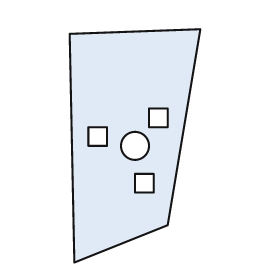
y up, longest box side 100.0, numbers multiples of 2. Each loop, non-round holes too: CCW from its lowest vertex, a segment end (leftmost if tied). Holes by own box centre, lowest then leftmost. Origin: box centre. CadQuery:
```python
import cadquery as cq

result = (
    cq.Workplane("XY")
    .moveTo(-26.0, -50.0)
    .lineTo(14.0, -34.0)
    .lineTo(28.0, 50.0)
    .lineTo(-28.0, 48.0)
    .close()
    .moveTo(0.0, -20.0)
    .lineTo(8.0, -20.0)
    .lineTo(8.0, -12.0)
    .lineTo(0.0, -12.0)
    .close()
    .moveTo(0.0, 0.0)
    .circle(6.0)
    .moveTo(-20.0, 0.0)
    .lineTo(-12.0, 0.0)
    .lineTo(-12.0, 8.0)
    .lineTo(-20.0, 8.0)
    .close()
    .moveTo(6.0, 8.0)
    .lineTo(14.0, 8.0)
    .lineTo(14.0, 16.0)
    .lineTo(6.0, 16.0)
    .close()
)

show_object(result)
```